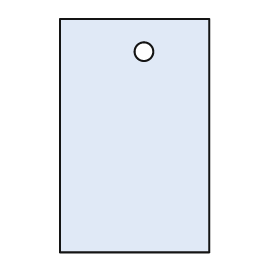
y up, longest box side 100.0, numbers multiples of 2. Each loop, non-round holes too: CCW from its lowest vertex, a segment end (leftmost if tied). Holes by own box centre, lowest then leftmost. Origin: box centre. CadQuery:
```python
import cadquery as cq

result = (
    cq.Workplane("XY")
    .moveTo(-32.0, -50.0)
    .lineTo(32.0, -50.0)
    .lineTo(32.0, 50.0)
    .lineTo(-32.0, 50.0)
    .close()
    .moveTo(4.0, 36.0)
    .circle(4.0)
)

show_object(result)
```